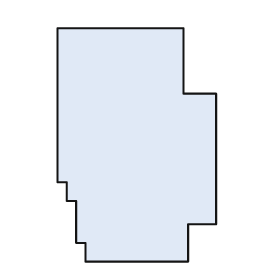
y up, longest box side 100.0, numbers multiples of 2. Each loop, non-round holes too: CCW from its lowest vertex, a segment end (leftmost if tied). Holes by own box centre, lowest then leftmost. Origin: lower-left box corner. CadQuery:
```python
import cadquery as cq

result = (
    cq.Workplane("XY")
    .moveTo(12.0, 0.0)
    .lineTo(56.0, 0.0)
    .lineTo(56.0, 16.0)
    .lineTo(68.0, 16.0)
    .lineTo(68.0, 72.0)
    .lineTo(54.0, 72.0)
    .lineTo(54.0, 100.0)
    .lineTo(0.0, 100.0)
    .lineTo(0.0, 34.0)
    .lineTo(4.0, 34.0)
    .lineTo(4.0, 26.0)
    .lineTo(8.0, 26.0)
    .lineTo(8.0, 8.0)
    .lineTo(12.0, 8.0)
    .close()
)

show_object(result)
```